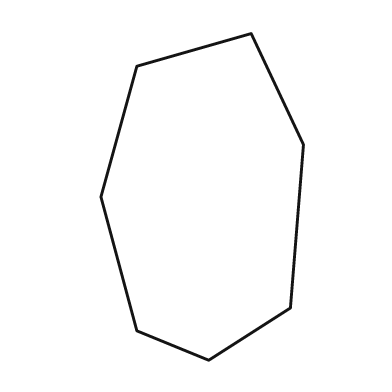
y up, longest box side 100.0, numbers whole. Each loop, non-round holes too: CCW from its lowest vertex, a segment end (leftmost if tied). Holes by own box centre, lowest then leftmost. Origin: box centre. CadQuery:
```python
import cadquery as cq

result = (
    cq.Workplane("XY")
    .moveTo(2.0, -50.0)
    .lineTo(27.0, -34.0)
    .lineTo(31.0, 16.0)
    .lineTo(15.0, 50.0)
    .lineTo(-20.0, 40.0)
    .lineTo(-31.0, 0.0)
    .lineTo(-20.0, -41.0)
    .close()
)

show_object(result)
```